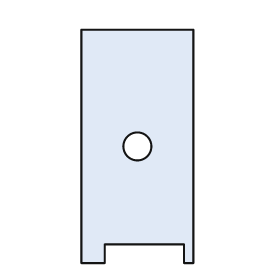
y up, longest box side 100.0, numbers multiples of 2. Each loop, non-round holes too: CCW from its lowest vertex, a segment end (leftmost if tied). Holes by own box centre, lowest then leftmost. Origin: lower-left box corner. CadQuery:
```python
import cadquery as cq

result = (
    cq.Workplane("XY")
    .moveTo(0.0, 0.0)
    .lineTo(10.0, 0.0)
    .lineTo(10.0, 8.0)
    .lineTo(44.0, 8.0)
    .lineTo(44.0, 0.0)
    .lineTo(48.0, 0.0)
    .lineTo(48.0, 100.0)
    .lineTo(0.0, 100.0)
    .close()
    .moveTo(24.0, 50.0)
    .circle(6.0)
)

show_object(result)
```